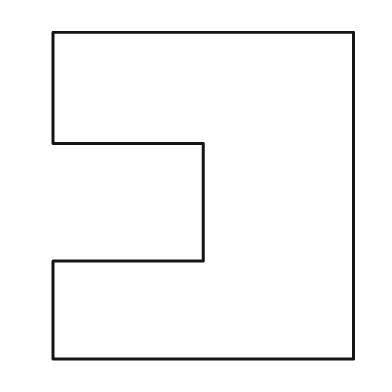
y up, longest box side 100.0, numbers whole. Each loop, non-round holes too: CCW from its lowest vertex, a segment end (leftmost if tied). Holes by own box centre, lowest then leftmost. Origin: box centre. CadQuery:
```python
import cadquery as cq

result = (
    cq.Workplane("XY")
    .moveTo(-46.0, -50.0)
    .lineTo(46.0, -50.0)
    .lineTo(46.0, 50.0)
    .lineTo(-46.0, 50.0)
    .lineTo(-46.0, 16.0)
    .lineTo(0.0, 16.0)
    .lineTo(0.0, -20.0)
    .lineTo(-46.0, -20.0)
    .close()
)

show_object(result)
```